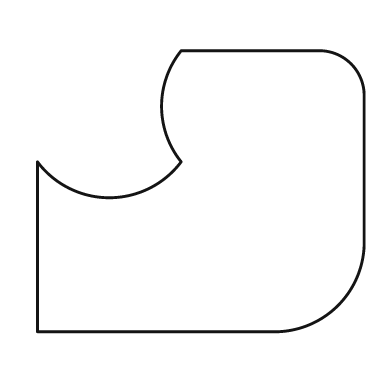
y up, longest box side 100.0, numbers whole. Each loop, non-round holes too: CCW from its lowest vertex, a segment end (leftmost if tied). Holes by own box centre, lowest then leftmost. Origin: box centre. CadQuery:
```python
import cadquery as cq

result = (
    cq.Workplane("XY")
    .moveTo(-50.0, -43.0)
    .lineTo(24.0, -43.0)
    .threePointArc((42.0, -35.0), (50.0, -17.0))
    .lineTo(50.0, 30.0)
    .threePointArc((46.0, 39.0), (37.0, 43.0))
    .lineTo(-6.0, 43.0)
    .threePointArc((-12.0, 26.0), (-6.0, 9.0))
    .threePointArc((-28.0, -2.0), (-50.0, 9.0))
    .close()
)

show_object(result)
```